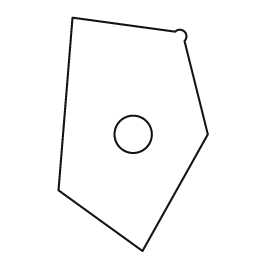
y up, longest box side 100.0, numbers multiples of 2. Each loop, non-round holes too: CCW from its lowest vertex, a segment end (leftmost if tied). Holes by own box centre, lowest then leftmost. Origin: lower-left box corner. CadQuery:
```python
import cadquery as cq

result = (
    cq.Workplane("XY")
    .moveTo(36.0, 0.0)
    .lineTo(64.0, 50.0)
    .lineTo(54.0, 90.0)
    .threePointArc((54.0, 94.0), (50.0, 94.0))
    .lineTo(6.0, 100.0)
    .lineTo(0.0, 26.0)
    .close()
    .moveTo(32.0, 50.0)
    .circle(8.0)
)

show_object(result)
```